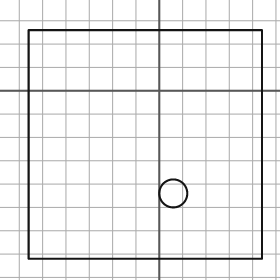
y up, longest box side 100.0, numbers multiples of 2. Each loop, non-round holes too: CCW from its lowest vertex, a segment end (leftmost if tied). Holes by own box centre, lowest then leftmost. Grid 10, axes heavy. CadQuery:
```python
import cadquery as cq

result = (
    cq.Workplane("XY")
    .moveTo(-56.0, -72.0)
    .lineTo(44.0, -72.0)
    .lineTo(44.0, 26.0)
    .lineTo(-56.0, 26.0)
    .close()
    .moveTo(6.0, -44.0)
    .circle(6.0)
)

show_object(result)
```